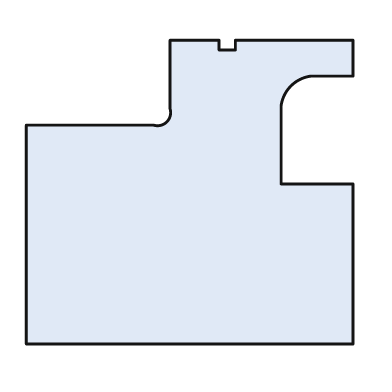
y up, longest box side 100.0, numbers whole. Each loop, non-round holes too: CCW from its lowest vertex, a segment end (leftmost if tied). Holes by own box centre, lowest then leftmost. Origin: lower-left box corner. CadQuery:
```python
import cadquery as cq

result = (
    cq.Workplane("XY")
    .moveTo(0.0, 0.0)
    .lineTo(100.0, 0.0)
    .lineTo(100.0, 49.0)
    .lineTo(78.0, 49.0)
    .lineTo(78.0, 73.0)
    .threePointArc((81.0, 79.0), (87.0, 82.0))
    .lineTo(100.0, 82.0)
    .lineTo(100.0, 93.0)
    .lineTo(64.0, 93.0)
    .lineTo(64.0, 90.0)
    .lineTo(59.0, 90.0)
    .lineTo(59.0, 93.0)
    .lineTo(44.0, 93.0)
    .lineTo(44.0, 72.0)
    .threePointArc((43.0, 68.0), (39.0, 67.0))
    .lineTo(0.0, 67.0)
    .close()
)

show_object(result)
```